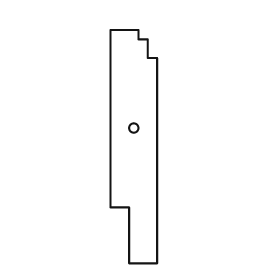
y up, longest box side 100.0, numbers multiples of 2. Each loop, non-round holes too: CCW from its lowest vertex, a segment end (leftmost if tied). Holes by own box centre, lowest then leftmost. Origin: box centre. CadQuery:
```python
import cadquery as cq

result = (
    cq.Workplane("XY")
    .moveTo(-2.0, -50.0)
    .lineTo(10.0, -50.0)
    .lineTo(10.0, 38.0)
    .lineTo(6.0, 38.0)
    .lineTo(6.0, 46.0)
    .lineTo(2.0, 46.0)
    .lineTo(2.0, 50.0)
    .lineTo(-10.0, 50.0)
    .lineTo(-10.0, -26.0)
    .lineTo(-2.0, -26.0)
    .close()
    .moveTo(0.0, 8.0)
    .circle(2.0)
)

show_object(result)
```